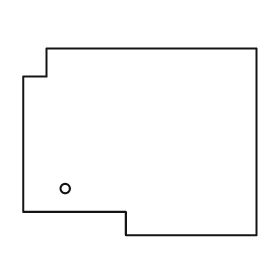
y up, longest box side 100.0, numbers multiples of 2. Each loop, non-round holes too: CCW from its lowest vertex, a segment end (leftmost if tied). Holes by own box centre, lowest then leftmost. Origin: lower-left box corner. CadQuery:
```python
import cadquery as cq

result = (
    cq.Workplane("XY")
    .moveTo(44.0, 0.0)
    .lineTo(100.0, 0.0)
    .lineTo(100.0, 80.0)
    .lineTo(10.0, 80.0)
    .lineTo(10.0, 68.0)
    .lineTo(0.0, 68.0)
    .lineTo(0.0, 10.0)
    .lineTo(44.0, 10.0)
    .close()
    .moveTo(18.0, 20.0)
    .circle(2.0)
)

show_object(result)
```